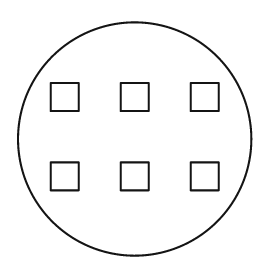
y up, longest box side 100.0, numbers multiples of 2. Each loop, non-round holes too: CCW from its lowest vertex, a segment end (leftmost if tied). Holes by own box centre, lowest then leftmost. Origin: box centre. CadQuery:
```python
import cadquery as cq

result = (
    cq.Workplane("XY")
    .moveTo(0.0, 0.0)
    .circle(50.0)
    .moveTo(-36.0, -22.0)
    .lineTo(-24.0, -22.0)
    .lineTo(-24.0, -10.0)
    .lineTo(-36.0, -10.0)
    .close()
    .moveTo(-6.0, -22.0)
    .lineTo(6.0, -22.0)
    .lineTo(6.0, -10.0)
    .lineTo(-6.0, -10.0)
    .close()
    .moveTo(24.0, -22.0)
    .lineTo(36.0, -22.0)
    .lineTo(36.0, -10.0)
    .lineTo(24.0, -10.0)
    .close()
    .moveTo(-36.0, 12.0)
    .lineTo(-24.0, 12.0)
    .lineTo(-24.0, 24.0)
    .lineTo(-36.0, 24.0)
    .close()
    .moveTo(-6.0, 12.0)
    .lineTo(6.0, 12.0)
    .lineTo(6.0, 24.0)
    .lineTo(-6.0, 24.0)
    .close()
    .moveTo(24.0, 12.0)
    .lineTo(36.0, 12.0)
    .lineTo(36.0, 24.0)
    .lineTo(24.0, 24.0)
    .close()
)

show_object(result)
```